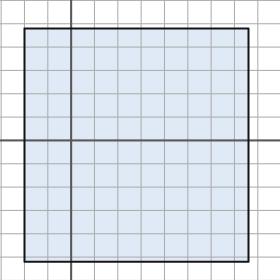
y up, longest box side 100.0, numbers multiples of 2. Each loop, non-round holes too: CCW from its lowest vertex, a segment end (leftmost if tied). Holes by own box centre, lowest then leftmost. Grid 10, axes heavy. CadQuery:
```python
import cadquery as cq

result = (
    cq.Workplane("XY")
    .moveTo(-20.0, -52.0)
    .lineTo(76.0, -52.0)
    .lineTo(76.0, 48.0)
    .lineTo(-20.0, 48.0)
    .close()
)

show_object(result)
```